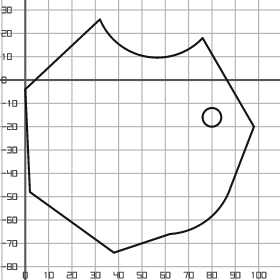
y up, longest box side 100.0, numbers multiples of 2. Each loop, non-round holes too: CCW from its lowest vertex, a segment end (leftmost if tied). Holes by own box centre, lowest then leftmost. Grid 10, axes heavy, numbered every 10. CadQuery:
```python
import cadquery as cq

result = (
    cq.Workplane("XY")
    .moveTo(38.0, -74.0)
    .lineTo(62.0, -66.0)
    .threePointArc((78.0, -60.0), (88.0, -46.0))
    .lineTo(98.0, -20.0)
    .lineTo(76.0, 18.0)
    .threePointArc((52.0, 10.0), (32.0, 26.0))
    .lineTo(0.0, -4.0)
    .lineTo(2.0, -48.0)
    .close()
    .moveTo(80.0, -16.0)
    .circle(4.0)
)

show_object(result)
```